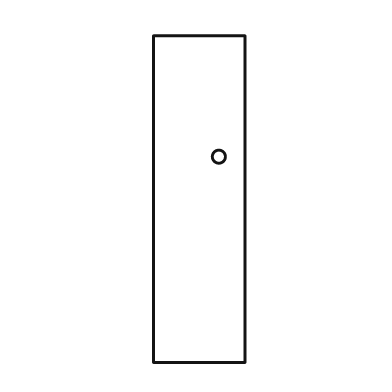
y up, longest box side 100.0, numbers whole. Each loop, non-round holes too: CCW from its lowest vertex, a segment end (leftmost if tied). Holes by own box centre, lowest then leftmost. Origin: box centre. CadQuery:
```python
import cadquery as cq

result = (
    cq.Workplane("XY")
    .moveTo(-14.0, -50.0)
    .lineTo(14.0, -50.0)
    .lineTo(14.0, 50.0)
    .lineTo(-14.0, 50.0)
    .close()
    .moveTo(6.0, 13.0)
    .circle(2.0)
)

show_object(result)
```